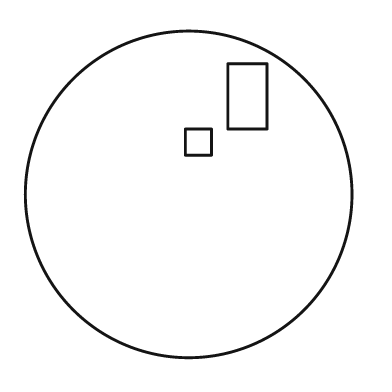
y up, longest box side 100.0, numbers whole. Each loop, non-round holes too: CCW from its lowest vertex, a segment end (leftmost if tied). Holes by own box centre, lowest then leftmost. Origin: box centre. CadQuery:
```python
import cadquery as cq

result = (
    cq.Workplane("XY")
    .moveTo(0.0, 0.0)
    .circle(50.0)
    .moveTo(-1.0, 12.0)
    .lineTo(7.0, 12.0)
    .lineTo(7.0, 20.0)
    .lineTo(-1.0, 20.0)
    .close()
    .moveTo(12.0, 20.0)
    .lineTo(24.0, 20.0)
    .lineTo(24.0, 40.0)
    .lineTo(12.0, 40.0)
    .close()
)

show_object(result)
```